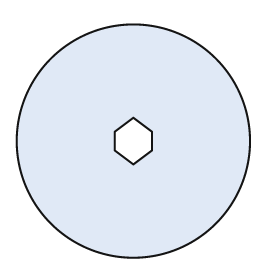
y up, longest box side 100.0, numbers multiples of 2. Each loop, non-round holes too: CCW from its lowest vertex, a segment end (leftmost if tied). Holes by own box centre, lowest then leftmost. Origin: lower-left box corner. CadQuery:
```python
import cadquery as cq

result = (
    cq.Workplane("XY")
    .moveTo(50.0, 50.0)
    .circle(50.0)
    .moveTo(50.0, 40.0)
    .lineTo(58.0, 46.0)
    .lineTo(58.0, 54.0)
    .lineTo(50.0, 60.0)
    .lineTo(42.0, 54.0)
    .lineTo(42.0, 46.0)
    .close()
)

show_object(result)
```